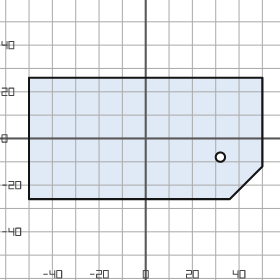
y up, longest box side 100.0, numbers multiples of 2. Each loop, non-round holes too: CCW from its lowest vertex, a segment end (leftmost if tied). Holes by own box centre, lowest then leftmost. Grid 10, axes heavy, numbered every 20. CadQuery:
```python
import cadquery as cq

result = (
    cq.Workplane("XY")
    .moveTo(-50.0, -26.0)
    .lineTo(36.0, -26.0)
    .lineTo(50.0, -12.0)
    .lineTo(50.0, 26.0)
    .lineTo(-50.0, 26.0)
    .close()
    .moveTo(32.0, -8.0)
    .circle(2.0)
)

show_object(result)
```